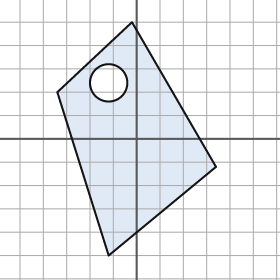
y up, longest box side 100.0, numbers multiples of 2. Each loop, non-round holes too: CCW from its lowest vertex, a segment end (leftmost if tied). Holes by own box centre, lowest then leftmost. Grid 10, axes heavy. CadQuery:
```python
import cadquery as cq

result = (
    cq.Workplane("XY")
    .moveTo(-12.0, -50.0)
    .lineTo(34.0, -12.0)
    .lineTo(-2.0, 50.0)
    .lineTo(-34.0, 20.0)
    .close()
    .moveTo(-12.0, 24.0)
    .circle(8.0)
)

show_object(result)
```